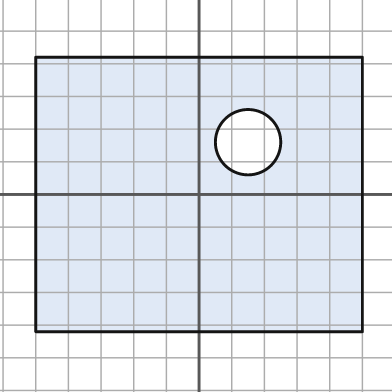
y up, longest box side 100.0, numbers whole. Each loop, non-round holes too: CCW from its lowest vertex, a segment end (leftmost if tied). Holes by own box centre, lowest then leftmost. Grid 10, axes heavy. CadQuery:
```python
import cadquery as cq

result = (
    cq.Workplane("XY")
    .moveTo(-50.0, -42.0)
    .lineTo(50.0, -42.0)
    .lineTo(50.0, 42.0)
    .lineTo(-50.0, 42.0)
    .close()
    .moveTo(15.0, 16.0)
    .circle(10.0)
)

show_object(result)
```